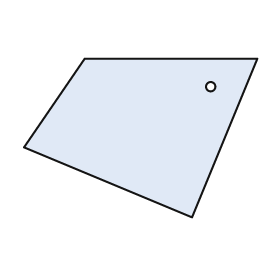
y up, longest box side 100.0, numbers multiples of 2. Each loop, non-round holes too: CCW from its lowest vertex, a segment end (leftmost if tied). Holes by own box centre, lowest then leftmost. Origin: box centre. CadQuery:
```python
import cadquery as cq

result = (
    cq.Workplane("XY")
    .moveTo(22.0, -34.0)
    .lineTo(50.0, 34.0)
    .lineTo(-24.0, 34.0)
    .lineTo(-50.0, -4.0)
    .close()
    .moveTo(30.0, 22.0)
    .circle(2.0)
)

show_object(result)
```